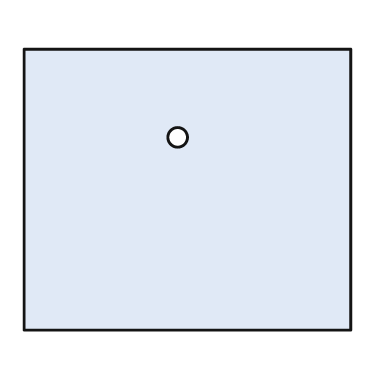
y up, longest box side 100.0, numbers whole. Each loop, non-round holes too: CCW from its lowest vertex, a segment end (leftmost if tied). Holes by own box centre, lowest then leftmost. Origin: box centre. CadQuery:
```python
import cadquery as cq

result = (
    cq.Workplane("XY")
    .moveTo(-50.0, -43.0)
    .lineTo(50.0, -43.0)
    .lineTo(50.0, 43.0)
    .lineTo(-50.0, 43.0)
    .close()
    .moveTo(-3.0, 16.0)
    .circle(3.0)
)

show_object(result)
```